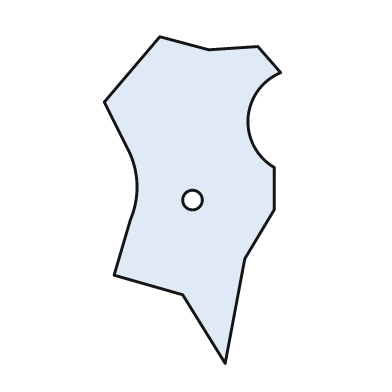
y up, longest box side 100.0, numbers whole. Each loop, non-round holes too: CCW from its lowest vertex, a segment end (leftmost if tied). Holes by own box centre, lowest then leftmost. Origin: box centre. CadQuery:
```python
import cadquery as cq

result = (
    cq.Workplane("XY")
    .moveTo(10.0, -50.0)
    .lineTo(16.0, -18.0)
    .lineTo(25.0, -3.0)
    .lineTo(25.0, 10.0)
    .threePointArc((17.0, 25.0), (27.0, 39.0))
    .lineTo(20.0, 47.0)
    .lineTo(5.0, 46.0)
    .lineTo(-10.0, 50.0)
    .lineTo(-27.0, 30.0)
    .lineTo(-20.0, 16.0)
    .threePointArc((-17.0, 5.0), (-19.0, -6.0))
    .lineTo(-24.0, -23.0)
    .lineTo(-3.0, -29.0)
    .close()
    .moveTo(0.0, 0.0)
    .circle(3.0)
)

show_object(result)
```